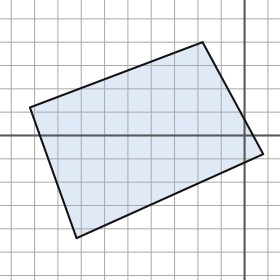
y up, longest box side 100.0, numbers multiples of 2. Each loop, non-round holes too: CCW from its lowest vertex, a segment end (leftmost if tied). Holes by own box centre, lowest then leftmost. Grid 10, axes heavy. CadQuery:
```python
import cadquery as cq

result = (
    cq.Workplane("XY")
    .moveTo(-72.0, -44.0)
    .lineTo(8.0, -8.0)
    .lineTo(-18.0, 40.0)
    .lineTo(-92.0, 12.0)
    .close()
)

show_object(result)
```